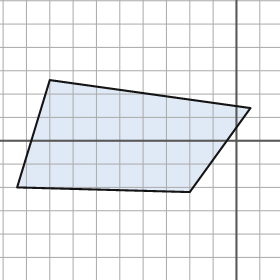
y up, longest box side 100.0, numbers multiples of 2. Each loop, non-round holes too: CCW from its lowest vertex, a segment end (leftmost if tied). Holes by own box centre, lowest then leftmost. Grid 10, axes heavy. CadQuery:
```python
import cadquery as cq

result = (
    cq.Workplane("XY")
    .moveTo(-20.0, -22.0)
    .lineTo(6.0, 14.0)
    .lineTo(-80.0, 26.0)
    .lineTo(-94.0, -20.0)
    .close()
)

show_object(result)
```